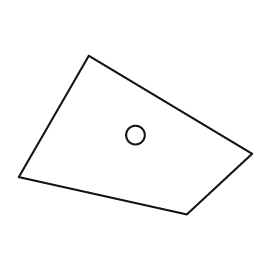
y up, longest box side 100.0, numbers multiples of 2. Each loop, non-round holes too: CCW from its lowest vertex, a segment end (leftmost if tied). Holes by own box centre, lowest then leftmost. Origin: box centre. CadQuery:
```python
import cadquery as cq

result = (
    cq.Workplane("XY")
    .moveTo(22.0, -34.0)
    .lineTo(50.0, -8.0)
    .lineTo(-20.0, 34.0)
    .lineTo(-50.0, -18.0)
    .close()
    .moveTo(0.0, 0.0)
    .circle(4.0)
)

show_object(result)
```